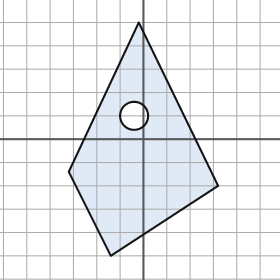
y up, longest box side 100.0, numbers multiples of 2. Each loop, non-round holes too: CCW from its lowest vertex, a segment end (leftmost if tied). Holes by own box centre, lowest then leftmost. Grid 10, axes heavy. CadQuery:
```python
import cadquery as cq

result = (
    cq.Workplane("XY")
    .moveTo(-14.0, -50.0)
    .lineTo(32.0, -20.0)
    .lineTo(-2.0, 50.0)
    .lineTo(-32.0, -14.0)
    .close()
    .moveTo(-4.0, 10.0)
    .circle(6.0)
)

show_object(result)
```